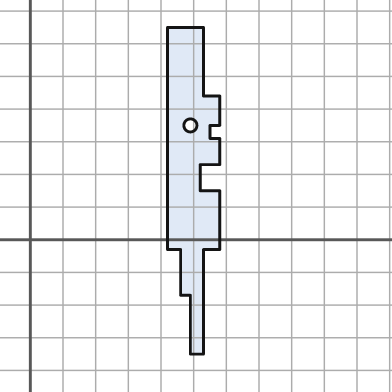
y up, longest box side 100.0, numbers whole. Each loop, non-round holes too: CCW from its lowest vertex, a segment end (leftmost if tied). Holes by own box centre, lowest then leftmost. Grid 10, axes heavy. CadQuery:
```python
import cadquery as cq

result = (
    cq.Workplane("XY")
    .moveTo(49.0, -35.0)
    .lineTo(53.0, -35.0)
    .lineTo(53.0, -3.0)
    .lineTo(58.0, -3.0)
    .lineTo(58.0, 15.0)
    .lineTo(52.0, 15.0)
    .lineTo(52.0, 23.0)
    .lineTo(58.0, 23.0)
    .lineTo(58.0, 31.0)
    .lineTo(55.0, 31.0)
    .lineTo(55.0, 35.0)
    .lineTo(58.0, 35.0)
    .lineTo(58.0, 44.0)
    .lineTo(53.0, 44.0)
    .lineTo(53.0, 65.0)
    .lineTo(42.0, 65.0)
    .lineTo(42.0, -3.0)
    .lineTo(46.0, -3.0)
    .lineTo(46.0, -17.0)
    .lineTo(49.0, -17.0)
    .close()
    .moveTo(49.0, 35.0)
    .circle(2.0)
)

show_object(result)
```